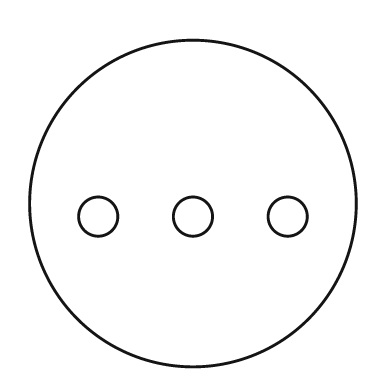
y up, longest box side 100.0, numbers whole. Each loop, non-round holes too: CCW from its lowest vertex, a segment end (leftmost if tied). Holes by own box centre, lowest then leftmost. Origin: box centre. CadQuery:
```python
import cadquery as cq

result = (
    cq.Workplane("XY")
    .moveTo(0.0, 0.0)
    .circle(50.0)
    .moveTo(-29.0, -4.0)
    .circle(6.0)
    .moveTo(0.0, -4.0)
    .circle(6.0)
    .moveTo(29.0, -4.0)
    .circle(6.0)
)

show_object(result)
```